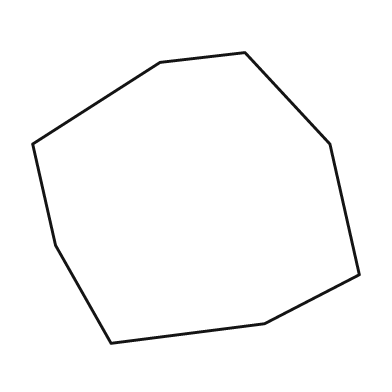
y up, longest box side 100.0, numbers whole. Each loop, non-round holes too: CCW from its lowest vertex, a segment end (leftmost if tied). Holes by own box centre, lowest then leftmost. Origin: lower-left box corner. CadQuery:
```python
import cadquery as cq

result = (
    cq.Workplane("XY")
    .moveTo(24.0, 0.0)
    .lineTo(71.0, 6.0)
    .lineTo(100.0, 21.0)
    .lineTo(91.0, 61.0)
    .lineTo(65.0, 89.0)
    .lineTo(39.0, 86.0)
    .lineTo(0.0, 61.0)
    .lineTo(7.0, 30.0)
    .close()
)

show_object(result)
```